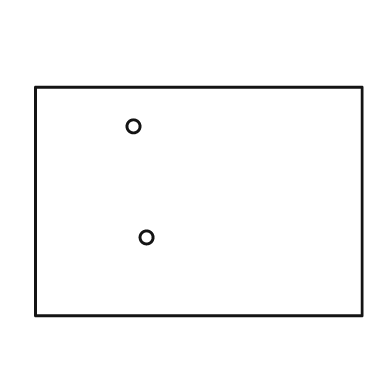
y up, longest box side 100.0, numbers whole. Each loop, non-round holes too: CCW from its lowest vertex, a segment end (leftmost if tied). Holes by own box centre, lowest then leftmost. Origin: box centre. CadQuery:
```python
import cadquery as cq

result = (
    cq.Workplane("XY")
    .moveTo(-50.0, -35.0)
    .lineTo(50.0, -35.0)
    .lineTo(50.0, 35.0)
    .lineTo(-50.0, 35.0)
    .close()
    .moveTo(-16.0, -11.0)
    .circle(2.0)
    .moveTo(-20.0, 23.0)
    .circle(2.0)
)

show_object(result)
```